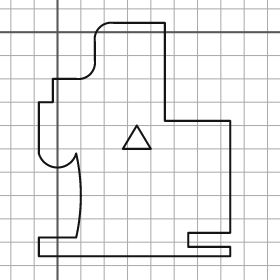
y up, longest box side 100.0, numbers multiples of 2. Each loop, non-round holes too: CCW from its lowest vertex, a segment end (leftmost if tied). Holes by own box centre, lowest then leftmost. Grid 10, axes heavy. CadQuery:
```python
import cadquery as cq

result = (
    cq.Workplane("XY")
    .moveTo(-8.0, -96.0)
    .lineTo(74.0, -96.0)
    .lineTo(74.0, -92.0)
    .lineTo(56.0, -92.0)
    .lineTo(56.0, -86.0)
    .lineTo(74.0, -86.0)
    .lineTo(74.0, -38.0)
    .lineTo(46.0, -38.0)
    .lineTo(46.0, 4.0)
    .lineTo(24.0, 4.0)
    .threePointArc((18.0, 2.0), (16.0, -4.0))
    .lineTo(16.0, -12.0)
    .threePointArc((14.0, -18.0), (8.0, -20.0))
    .lineTo(-2.0, -20.0)
    .lineTo(-2.0, -30.0)
    .lineTo(-8.0, -30.0)
    .lineTo(-8.0, -52.0)
    .threePointArc((0.0, -58.0), (8.0, -52.0))
    .threePointArc((10.0, -70.0), (8.0, -88.0))
    .lineTo(-8.0, -88.0)
    .close()
    .moveTo(28.0, -50.0)
    .lineTo(40.0, -50.0)
    .lineTo(34.0, -40.0)
    .close()
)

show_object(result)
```